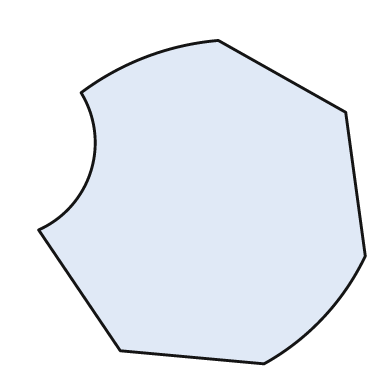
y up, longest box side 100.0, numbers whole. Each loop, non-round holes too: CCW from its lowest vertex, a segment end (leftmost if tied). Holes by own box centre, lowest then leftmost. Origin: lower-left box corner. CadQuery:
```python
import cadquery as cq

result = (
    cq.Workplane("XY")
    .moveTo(69.0, 0.0)
    .threePointArc((87.0, 14.0), (100.0, 33.0))
    .lineTo(94.0, 77.0)
    .lineTo(55.0, 99.0)
    .threePointArc((33.0, 94.0), (13.0, 83.0))
    .threePointArc((16.0, 59.0), (0.0, 41.0))
    .lineTo(25.0, 4.0)
    .close()
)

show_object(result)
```